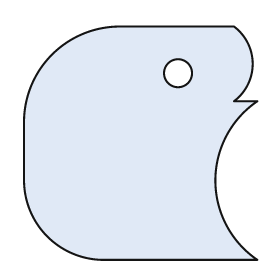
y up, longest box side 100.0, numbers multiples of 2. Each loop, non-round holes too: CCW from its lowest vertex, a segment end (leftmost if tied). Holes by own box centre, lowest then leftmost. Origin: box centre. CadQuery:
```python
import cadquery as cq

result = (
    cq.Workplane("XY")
    .moveTo(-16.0, -50.0)
    .lineTo(50.0, -50.0)
    .threePointArc((32.0, -16.0), (50.0, 18.0))
    .lineTo(40.0, 18.0)
    .threePointArc((48.0, 34.0), (40.0, 50.0))
    .lineTo(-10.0, 50.0)
    .threePointArc((-38.0, 38.0), (-50.0, 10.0))
    .lineTo(-50.0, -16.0)
    .threePointArc((-40.0, -40.0), (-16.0, -50.0))
    .close()
    .moveTo(16.0, 30.0)
    .circle(6.0)
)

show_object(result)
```